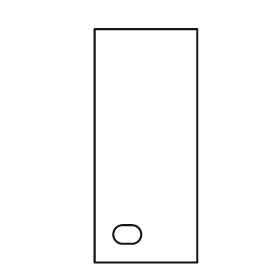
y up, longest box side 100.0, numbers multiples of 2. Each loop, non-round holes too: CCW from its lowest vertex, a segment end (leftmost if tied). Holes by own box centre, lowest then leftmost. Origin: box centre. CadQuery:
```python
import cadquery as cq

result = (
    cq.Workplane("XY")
    .moveTo(-22.0, -50.0)
    .lineTo(22.0, -50.0)
    .lineTo(22.0, 50.0)
    .lineTo(-22.0, 50.0)
    .close()
    .moveTo(-10.0, -42.0)
    .lineTo(-6.0, -42.0)
    .threePointArc((-2.0, -38.0), (-6.0, -34.0))
    .lineTo(-10.0, -34.0)
    .threePointArc((-14.0, -38.0), (-10.0, -42.0))
    .close()
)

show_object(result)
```